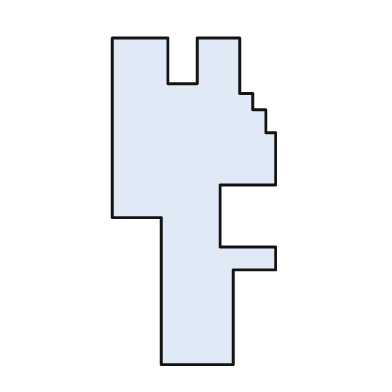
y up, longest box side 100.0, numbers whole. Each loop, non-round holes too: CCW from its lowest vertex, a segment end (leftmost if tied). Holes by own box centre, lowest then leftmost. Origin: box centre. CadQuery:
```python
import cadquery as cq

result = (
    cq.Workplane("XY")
    .moveTo(-10.0, -50.0)
    .lineTo(12.0, -50.0)
    .lineTo(12.0, -21.0)
    .lineTo(25.0, -21.0)
    .lineTo(25.0, -14.0)
    .lineTo(8.0, -14.0)
    .lineTo(8.0, 5.0)
    .lineTo(25.0, 5.0)
    .lineTo(25.0, 21.0)
    .lineTo(22.0, 21.0)
    .lineTo(22.0, 28.0)
    .lineTo(18.0, 28.0)
    .lineTo(18.0, 33.0)
    .lineTo(14.0, 33.0)
    .lineTo(14.0, 50.0)
    .lineTo(1.0, 50.0)
    .lineTo(1.0, 36.0)
    .lineTo(-8.0, 36.0)
    .lineTo(-8.0, 50.0)
    .lineTo(-25.0, 50.0)
    .lineTo(-25.0, -5.0)
    .lineTo(-10.0, -5.0)
    .close()
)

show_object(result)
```